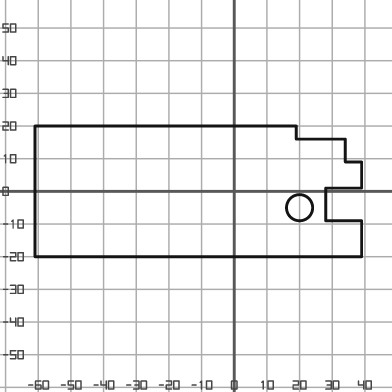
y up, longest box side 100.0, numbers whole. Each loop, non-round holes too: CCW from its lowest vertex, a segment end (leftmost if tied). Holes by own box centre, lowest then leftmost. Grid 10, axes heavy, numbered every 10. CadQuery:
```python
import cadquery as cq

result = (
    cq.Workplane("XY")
    .moveTo(-61.0, -20.0)
    .lineTo(39.0, -20.0)
    .lineTo(39.0, -9.0)
    .lineTo(28.0, -9.0)
    .lineTo(28.0, 1.0)
    .lineTo(39.0, 1.0)
    .lineTo(39.0, 9.0)
    .lineTo(34.0, 9.0)
    .lineTo(34.0, 16.0)
    .lineTo(19.0, 16.0)
    .lineTo(19.0, 20.0)
    .lineTo(-61.0, 20.0)
    .close()
    .moveTo(20.0, -5.0)
    .circle(4.0)
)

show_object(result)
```